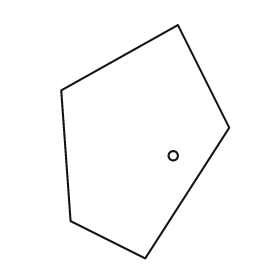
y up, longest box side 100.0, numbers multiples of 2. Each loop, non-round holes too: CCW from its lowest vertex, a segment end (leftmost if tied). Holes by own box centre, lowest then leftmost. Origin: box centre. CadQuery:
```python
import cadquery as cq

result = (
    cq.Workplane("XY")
    .moveTo(0.0, -50.0)
    .lineTo(36.0, 6.0)
    .lineTo(14.0, 50.0)
    .lineTo(-36.0, 22.0)
    .lineTo(-32.0, -34.0)
    .close()
    .moveTo(12.0, -6.0)
    .circle(2.0)
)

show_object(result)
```